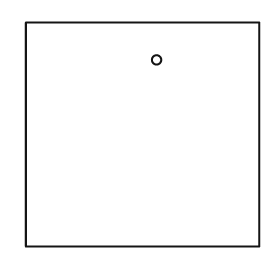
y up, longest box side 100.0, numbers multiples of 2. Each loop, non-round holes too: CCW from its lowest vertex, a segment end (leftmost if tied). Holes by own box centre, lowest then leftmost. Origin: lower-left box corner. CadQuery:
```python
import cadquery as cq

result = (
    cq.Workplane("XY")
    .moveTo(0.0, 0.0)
    .lineTo(100.0, 0.0)
    .lineTo(100.0, 96.0)
    .lineTo(0.0, 96.0)
    .close()
    .moveTo(56.0, 80.0)
    .circle(2.0)
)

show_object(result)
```